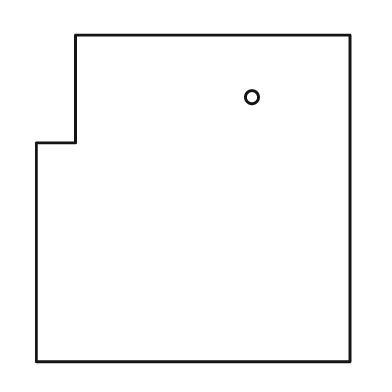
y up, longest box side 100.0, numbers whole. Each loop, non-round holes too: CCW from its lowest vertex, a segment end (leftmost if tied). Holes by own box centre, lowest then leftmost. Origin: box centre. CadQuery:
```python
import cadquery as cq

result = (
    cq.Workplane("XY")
    .moveTo(-48.0, -50.0)
    .lineTo(48.0, -50.0)
    .lineTo(48.0, 50.0)
    .lineTo(-36.0, 50.0)
    .lineTo(-36.0, 17.0)
    .lineTo(-48.0, 17.0)
    .close()
    .moveTo(18.0, 31.0)
    .circle(2.0)
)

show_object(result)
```